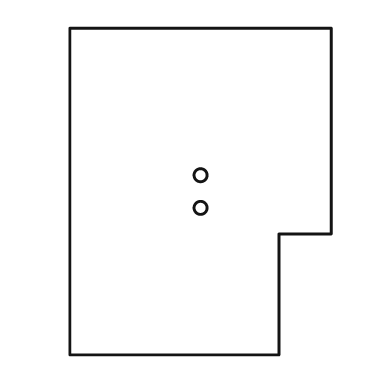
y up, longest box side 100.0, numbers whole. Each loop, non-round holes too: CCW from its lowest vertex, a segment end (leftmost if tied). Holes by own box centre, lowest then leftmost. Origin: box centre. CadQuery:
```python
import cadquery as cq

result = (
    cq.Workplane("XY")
    .moveTo(-40.0, -50.0)
    .lineTo(24.0, -50.0)
    .lineTo(24.0, -13.0)
    .lineTo(40.0, -13.0)
    .lineTo(40.0, 50.0)
    .lineTo(-40.0, 50.0)
    .close()
    .moveTo(0.0, -5.0)
    .circle(2.0)
    .moveTo(0.0, 5.0)
    .circle(2.0)
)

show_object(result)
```